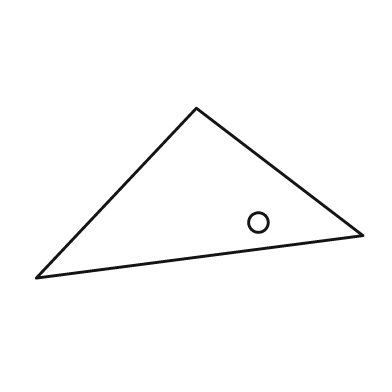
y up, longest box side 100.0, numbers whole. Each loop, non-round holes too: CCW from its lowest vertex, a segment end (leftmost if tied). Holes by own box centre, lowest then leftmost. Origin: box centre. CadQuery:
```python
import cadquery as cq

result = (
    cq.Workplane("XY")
    .moveTo(-50.0, -26.0)
    .lineTo(50.0, -13.0)
    .lineTo(-1.0, 26.0)
    .close()
    .moveTo(18.0, -9.0)
    .circle(3.0)
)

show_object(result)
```